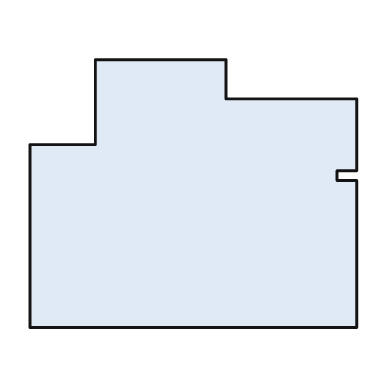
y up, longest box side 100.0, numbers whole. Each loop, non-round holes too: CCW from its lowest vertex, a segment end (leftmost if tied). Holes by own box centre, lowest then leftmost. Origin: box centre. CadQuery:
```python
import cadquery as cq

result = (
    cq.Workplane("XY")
    .moveTo(-50.0, -41.0)
    .lineTo(50.0, -41.0)
    .lineTo(50.0, 4.0)
    .lineTo(44.0, 4.0)
    .lineTo(44.0, 7.0)
    .lineTo(50.0, 7.0)
    .lineTo(50.0, 29.0)
    .lineTo(10.0, 29.0)
    .lineTo(10.0, 41.0)
    .lineTo(-30.0, 41.0)
    .lineTo(-30.0, 15.0)
    .lineTo(-50.0, 15.0)
    .close()
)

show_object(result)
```